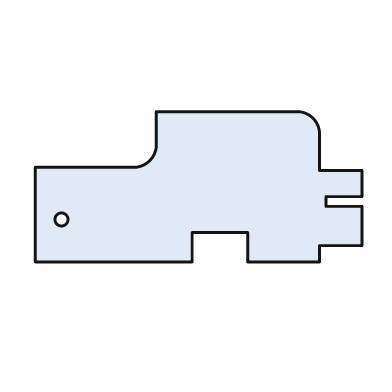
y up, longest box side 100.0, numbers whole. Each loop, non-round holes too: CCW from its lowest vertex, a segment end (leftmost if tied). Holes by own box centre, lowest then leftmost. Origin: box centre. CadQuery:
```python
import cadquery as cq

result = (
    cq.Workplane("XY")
    .moveTo(-50.0, -23.0)
    .lineTo(-2.0, -23.0)
    .lineTo(-2.0, -14.0)
    .lineTo(15.0, -14.0)
    .lineTo(15.0, -23.0)
    .lineTo(37.0, -23.0)
    .lineTo(37.0, -18.0)
    .lineTo(50.0, -18.0)
    .lineTo(50.0, -6.0)
    .lineTo(39.0, -6.0)
    .lineTo(39.0, -3.0)
    .lineTo(50.0, -3.0)
    .lineTo(50.0, 5.0)
    .lineTo(37.0, 5.0)
    .lineTo(37.0, 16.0)
    .threePointArc((35.0, 21.0), (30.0, 23.0))
    .lineTo(-13.0, 23.0)
    .lineTo(-13.0, 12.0)
    .threePointArc((-15.0, 8.0), (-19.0, 6.0))
    .lineTo(-50.0, 6.0)
    .close()
    .moveTo(-42.0, -10.0)
    .circle(2.0)
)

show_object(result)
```